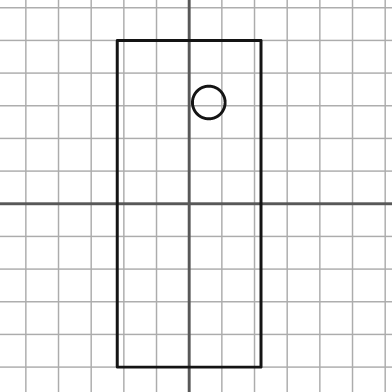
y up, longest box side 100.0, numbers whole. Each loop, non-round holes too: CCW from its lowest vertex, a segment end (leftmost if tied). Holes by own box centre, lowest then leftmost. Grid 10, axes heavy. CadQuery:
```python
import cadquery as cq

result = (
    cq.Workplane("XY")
    .moveTo(-22.0, -50.0)
    .lineTo(22.0, -50.0)
    .lineTo(22.0, 50.0)
    .lineTo(-22.0, 50.0)
    .close()
    .moveTo(6.0, 31.0)
    .circle(5.0)
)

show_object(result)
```